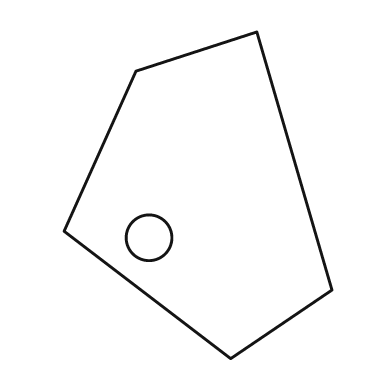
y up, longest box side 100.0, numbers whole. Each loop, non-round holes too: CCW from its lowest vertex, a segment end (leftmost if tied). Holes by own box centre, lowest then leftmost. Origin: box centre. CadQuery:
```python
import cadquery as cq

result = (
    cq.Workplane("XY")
    .moveTo(10.0, -50.0)
    .lineTo(41.0, -29.0)
    .lineTo(18.0, 50.0)
    .lineTo(-19.0, 38.0)
    .lineTo(-41.0, -11.0)
    .close()
    .moveTo(-15.0, -13.0)
    .circle(7.0)
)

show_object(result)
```